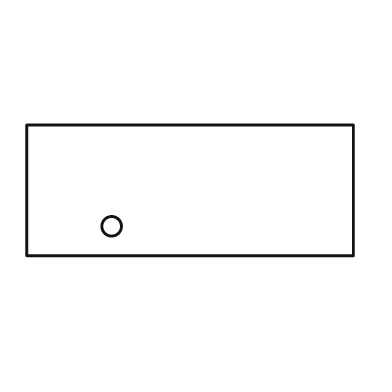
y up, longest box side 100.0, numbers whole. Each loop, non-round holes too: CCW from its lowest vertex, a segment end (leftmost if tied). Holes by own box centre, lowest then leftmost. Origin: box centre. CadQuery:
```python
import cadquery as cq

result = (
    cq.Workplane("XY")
    .moveTo(-50.0, -20.0)
    .lineTo(50.0, -20.0)
    .lineTo(50.0, 20.0)
    .lineTo(-50.0, 20.0)
    .close()
    .moveTo(-24.0, -11.0)
    .circle(3.0)
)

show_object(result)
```